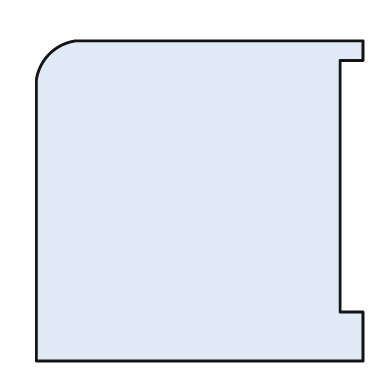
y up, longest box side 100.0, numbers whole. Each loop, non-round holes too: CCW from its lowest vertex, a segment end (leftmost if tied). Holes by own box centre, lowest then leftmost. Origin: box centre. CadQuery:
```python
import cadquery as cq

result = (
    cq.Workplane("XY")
    .moveTo(-50.0, -49.0)
    .lineTo(50.0, -49.0)
    .lineTo(50.0, -34.0)
    .lineTo(43.0, -34.0)
    .lineTo(43.0, 43.0)
    .lineTo(50.0, 43.0)
    .lineTo(50.0, 49.0)
    .lineTo(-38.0, 49.0)
    .threePointArc((-46.0, 45.0), (-50.0, 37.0))
    .close()
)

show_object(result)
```